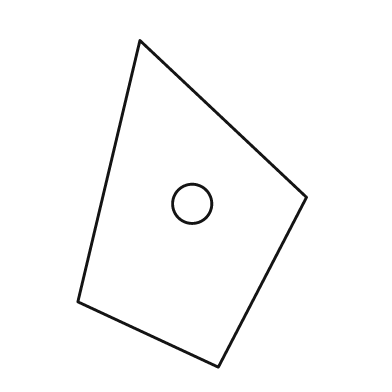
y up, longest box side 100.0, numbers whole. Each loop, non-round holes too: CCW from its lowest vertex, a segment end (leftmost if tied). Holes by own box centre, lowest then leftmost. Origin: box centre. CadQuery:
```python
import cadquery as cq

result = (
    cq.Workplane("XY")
    .moveTo(8.0, -50.0)
    .lineTo(35.0, 2.0)
    .lineTo(-16.0, 50.0)
    .lineTo(-35.0, -30.0)
    .close()
    .moveTo(0.0, 0.0)
    .circle(6.0)
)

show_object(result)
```